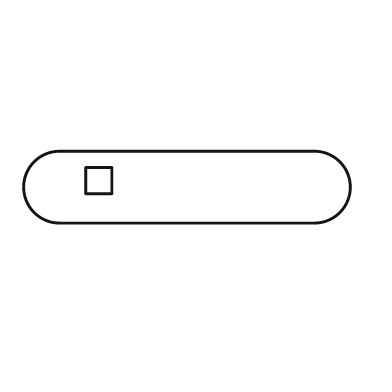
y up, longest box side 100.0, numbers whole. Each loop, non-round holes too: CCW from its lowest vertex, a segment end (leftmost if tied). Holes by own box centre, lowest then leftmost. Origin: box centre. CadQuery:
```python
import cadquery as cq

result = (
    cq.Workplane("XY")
    .moveTo(-39.0, -11.0)
    .lineTo(39.0, -11.0)
    .threePointArc((50.0, 0.0), (39.0, 11.0))
    .lineTo(-39.0, 11.0)
    .threePointArc((-50.0, 0.0), (-39.0, -11.0))
    .close()
    .moveTo(-31.0, -2.0)
    .lineTo(-23.0, -2.0)
    .lineTo(-23.0, 6.0)
    .lineTo(-31.0, 6.0)
    .close()
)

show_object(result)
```